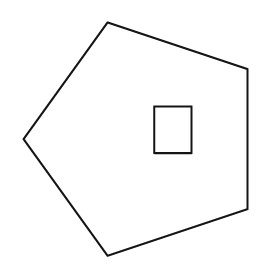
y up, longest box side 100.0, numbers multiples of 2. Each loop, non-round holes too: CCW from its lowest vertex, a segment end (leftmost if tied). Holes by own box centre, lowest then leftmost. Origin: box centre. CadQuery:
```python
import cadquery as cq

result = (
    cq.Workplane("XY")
    .moveTo(-12.0, -50.0)
    .lineTo(48.0, -30.0)
    .lineTo(48.0, 30.0)
    .lineTo(-12.0, 50.0)
    .lineTo(-48.0, 0.0)
    .close()
    .moveTo(8.0, -6.0)
    .lineTo(24.0, -6.0)
    .lineTo(24.0, 14.0)
    .lineTo(8.0, 14.0)
    .close()
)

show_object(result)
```